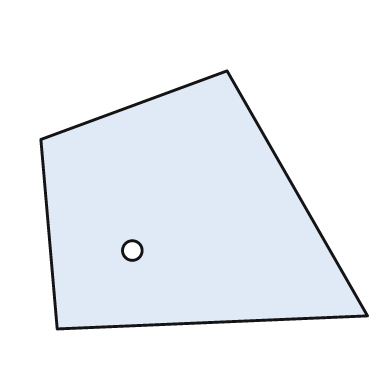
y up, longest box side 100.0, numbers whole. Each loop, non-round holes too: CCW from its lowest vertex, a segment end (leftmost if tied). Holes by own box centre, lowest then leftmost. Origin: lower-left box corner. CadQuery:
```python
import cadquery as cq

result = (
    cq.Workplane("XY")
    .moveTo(5.0, 0.0)
    .lineTo(100.0, 4.0)
    .lineTo(57.0, 79.0)
    .lineTo(0.0, 58.0)
    .close()
    .moveTo(28.0, 24.0)
    .circle(3.0)
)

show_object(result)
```